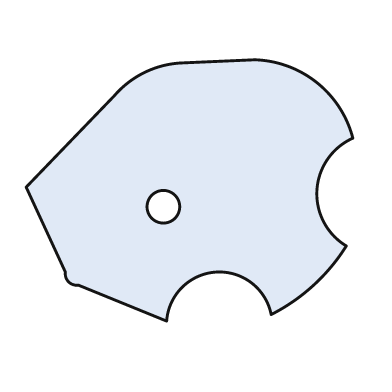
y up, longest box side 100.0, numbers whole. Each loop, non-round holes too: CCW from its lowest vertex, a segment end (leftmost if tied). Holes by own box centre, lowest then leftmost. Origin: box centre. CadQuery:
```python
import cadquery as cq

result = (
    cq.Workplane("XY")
    .moveTo(-7.0, -40.0)
    .threePointArc((8.0, -25.0), (25.0, -38.0))
    .threePointArc((38.0, -29.0), (48.0, -17.0))
    .threePointArc((39.0, 0.0), (50.0, 16.0))
    .threePointArc((39.0, 33.0), (20.0, 40.0))
    .lineTo(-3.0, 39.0)
    .threePointArc((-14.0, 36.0), (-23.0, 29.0))
    .lineTo(-50.0, 1.0)
    .lineTo(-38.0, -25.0)
    .threePointArc((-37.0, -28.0), (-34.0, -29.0))
    .close()
    .moveTo(-8.0, -5.0)
    .circle(5.0)
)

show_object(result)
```